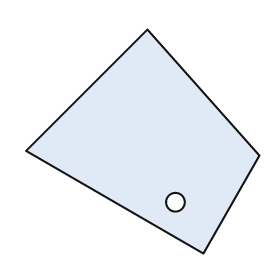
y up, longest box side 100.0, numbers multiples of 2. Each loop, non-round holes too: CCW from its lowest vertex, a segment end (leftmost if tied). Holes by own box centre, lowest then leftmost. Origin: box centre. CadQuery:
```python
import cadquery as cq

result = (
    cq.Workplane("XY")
    .moveTo(26.0, -48.0)
    .lineTo(50.0, -6.0)
    .lineTo(2.0, 48.0)
    .lineTo(-50.0, -4.0)
    .close()
    .moveTo(14.0, -26.0)
    .circle(4.0)
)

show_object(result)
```